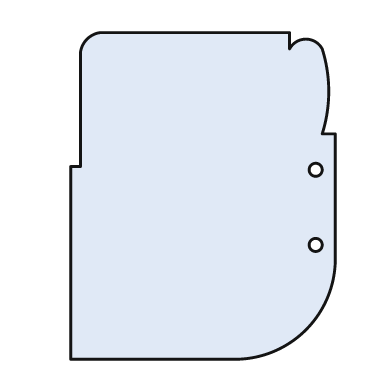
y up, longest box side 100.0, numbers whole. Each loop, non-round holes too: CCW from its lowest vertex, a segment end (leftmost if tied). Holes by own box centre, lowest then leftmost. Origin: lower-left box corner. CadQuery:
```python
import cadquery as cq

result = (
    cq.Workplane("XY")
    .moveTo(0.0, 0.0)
    .lineTo(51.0, 0.0)
    .threePointArc((72.0, 9.0), (81.0, 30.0))
    .lineTo(81.0, 69.0)
    .lineTo(77.0, 69.0)
    .threePointArc((79.0, 82.0), (77.0, 95.0))
    .threePointArc((72.0, 98.0), (67.0, 95.0))
    .lineTo(67.0, 100.0)
    .lineTo(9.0, 100.0)
    .threePointArc((5.0, 98.0), (3.0, 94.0))
    .lineTo(3.0, 59.0)
    .lineTo(0.0, 59.0)
    .close()
    .moveTo(75.0, 35.0)
    .circle(2.0)
    .moveTo(75.0, 58.0)
    .circle(2.0)
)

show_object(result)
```